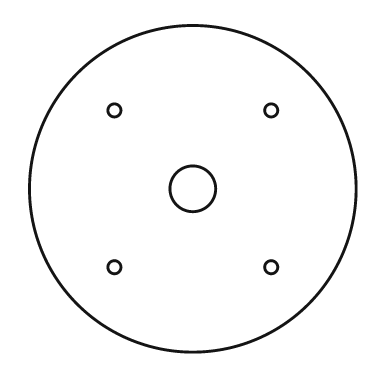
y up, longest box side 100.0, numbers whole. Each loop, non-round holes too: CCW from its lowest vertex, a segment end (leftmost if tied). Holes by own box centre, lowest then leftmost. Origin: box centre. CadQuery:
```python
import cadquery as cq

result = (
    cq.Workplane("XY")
    .moveTo(0.0, 0.0)
    .circle(50.0)
    .moveTo(-24.0, -24.0)
    .circle(2.0)
    .moveTo(24.0, -24.0)
    .circle(2.0)
    .moveTo(0.0, 0.0)
    .circle(7.0)
    .moveTo(-24.0, 24.0)
    .circle(2.0)
    .moveTo(24.0, 24.0)
    .circle(2.0)
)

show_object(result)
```